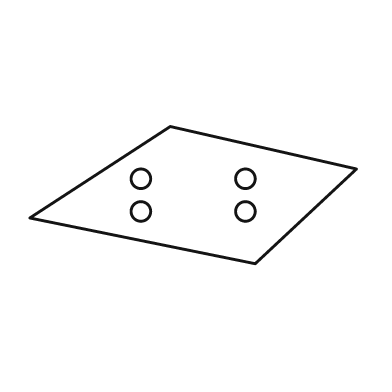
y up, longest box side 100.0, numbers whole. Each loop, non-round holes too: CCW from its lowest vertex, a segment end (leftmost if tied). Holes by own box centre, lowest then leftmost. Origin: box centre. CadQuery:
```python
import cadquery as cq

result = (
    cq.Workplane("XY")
    .moveTo(19.0, -21.0)
    .lineTo(50.0, 8.0)
    .lineTo(-7.0, 21.0)
    .lineTo(-50.0, -7.0)
    .close()
    .moveTo(-16.0, -5.0)
    .circle(3.0)
    .moveTo(16.0, -5.0)
    .circle(3.0)
    .moveTo(-16.0, 5.0)
    .circle(3.0)
    .moveTo(16.0, 5.0)
    .circle(3.0)
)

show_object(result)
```